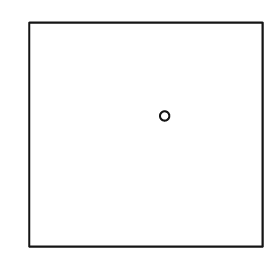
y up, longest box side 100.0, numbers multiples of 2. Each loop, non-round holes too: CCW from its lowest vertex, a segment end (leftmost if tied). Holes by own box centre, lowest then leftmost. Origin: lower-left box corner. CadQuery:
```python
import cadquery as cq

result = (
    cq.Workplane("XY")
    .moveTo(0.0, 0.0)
    .lineTo(100.0, 0.0)
    .lineTo(100.0, 96.0)
    .lineTo(0.0, 96.0)
    .close()
    .moveTo(58.0, 56.0)
    .circle(2.0)
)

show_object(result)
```